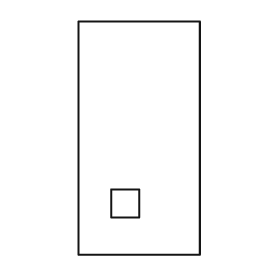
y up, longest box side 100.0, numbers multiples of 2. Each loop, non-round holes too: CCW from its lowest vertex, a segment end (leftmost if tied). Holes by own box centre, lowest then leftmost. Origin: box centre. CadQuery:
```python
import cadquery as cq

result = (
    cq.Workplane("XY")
    .moveTo(-26.0, -50.0)
    .lineTo(26.0, -50.0)
    .lineTo(26.0, 50.0)
    .lineTo(-26.0, 50.0)
    .close()
    .moveTo(-12.0, -34.0)
    .lineTo(0.0, -34.0)
    .lineTo(0.0, -22.0)
    .lineTo(-12.0, -22.0)
    .close()
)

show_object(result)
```